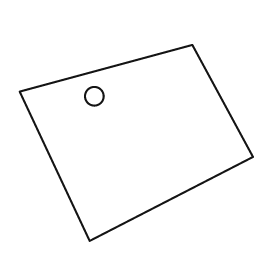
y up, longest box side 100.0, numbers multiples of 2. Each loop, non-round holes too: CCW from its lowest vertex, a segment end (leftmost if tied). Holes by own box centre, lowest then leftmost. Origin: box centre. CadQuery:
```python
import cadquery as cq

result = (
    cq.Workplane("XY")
    .moveTo(-20.0, -42.0)
    .lineTo(50.0, -6.0)
    .lineTo(24.0, 42.0)
    .lineTo(-50.0, 22.0)
    .close()
    .moveTo(-18.0, 20.0)
    .circle(4.0)
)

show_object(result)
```